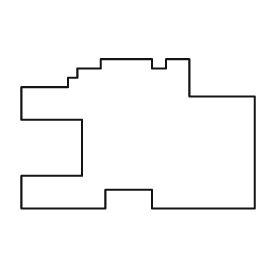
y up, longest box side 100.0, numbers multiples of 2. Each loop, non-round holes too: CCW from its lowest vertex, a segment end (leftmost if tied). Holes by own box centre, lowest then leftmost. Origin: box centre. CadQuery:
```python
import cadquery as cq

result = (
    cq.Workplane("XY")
    .moveTo(-50.0, -32.0)
    .lineTo(-14.0, -32.0)
    .lineTo(-14.0, -24.0)
    .lineTo(6.0, -24.0)
    .lineTo(6.0, -32.0)
    .lineTo(50.0, -32.0)
    .lineTo(50.0, 16.0)
    .lineTo(22.0, 16.0)
    .lineTo(22.0, 32.0)
    .lineTo(12.0, 32.0)
    .lineTo(12.0, 28.0)
    .lineTo(6.0, 28.0)
    .lineTo(6.0, 32.0)
    .lineTo(-16.0, 32.0)
    .lineTo(-16.0, 28.0)
    .lineTo(-26.0, 28.0)
    .lineTo(-26.0, 24.0)
    .lineTo(-30.0, 24.0)
    .lineTo(-30.0, 20.0)
    .lineTo(-50.0, 20.0)
    .lineTo(-50.0, 6.0)
    .lineTo(-24.0, 6.0)
    .lineTo(-24.0, -18.0)
    .lineTo(-50.0, -18.0)
    .close()
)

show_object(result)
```